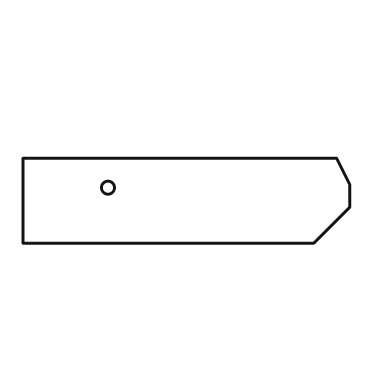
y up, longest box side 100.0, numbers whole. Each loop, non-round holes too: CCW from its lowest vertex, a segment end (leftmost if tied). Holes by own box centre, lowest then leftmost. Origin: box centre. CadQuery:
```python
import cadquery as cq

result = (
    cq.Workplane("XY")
    .moveTo(-50.0, -13.0)
    .lineTo(39.0, -13.0)
    .lineTo(50.0, -2.0)
    .lineTo(50.0, 5.0)
    .lineTo(46.0, 13.0)
    .lineTo(-50.0, 13.0)
    .close()
    .moveTo(-24.0, 4.0)
    .circle(2.0)
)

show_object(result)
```